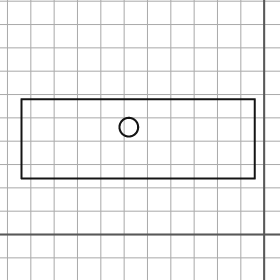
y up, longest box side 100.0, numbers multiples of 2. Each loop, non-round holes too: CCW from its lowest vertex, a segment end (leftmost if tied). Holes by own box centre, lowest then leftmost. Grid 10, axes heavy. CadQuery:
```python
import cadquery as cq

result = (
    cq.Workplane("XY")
    .moveTo(-104.0, 24.0)
    .lineTo(-4.0, 24.0)
    .lineTo(-4.0, 58.0)
    .lineTo(-104.0, 58.0)
    .close()
    .moveTo(-58.0, 46.0)
    .circle(4.0)
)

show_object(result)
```